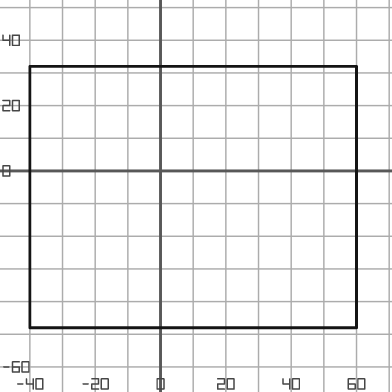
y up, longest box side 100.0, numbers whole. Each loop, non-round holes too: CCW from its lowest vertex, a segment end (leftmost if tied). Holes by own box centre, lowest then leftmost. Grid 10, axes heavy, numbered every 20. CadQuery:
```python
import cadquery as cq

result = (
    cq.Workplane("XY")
    .moveTo(-40.0, -48.0)
    .lineTo(60.0, -48.0)
    .lineTo(60.0, 32.0)
    .lineTo(-40.0, 32.0)
    .close()
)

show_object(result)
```